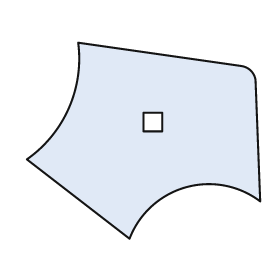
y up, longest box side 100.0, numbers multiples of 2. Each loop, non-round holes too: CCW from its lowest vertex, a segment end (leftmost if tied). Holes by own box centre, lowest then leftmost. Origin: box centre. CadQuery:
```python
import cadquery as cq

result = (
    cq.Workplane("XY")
    .moveTo(-6.0, -42.0)
    .threePointArc((18.0, -20.0), (50.0, -26.0))
    .lineTo(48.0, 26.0)
    .threePointArc((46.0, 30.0), (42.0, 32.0))
    .lineTo(-28.0, 42.0)
    .threePointArc((-32.0, 14.0), (-50.0, -8.0))
    .close()
    .moveTo(0.0, 4.0)
    .lineTo(8.0, 4.0)
    .lineTo(8.0, 12.0)
    .lineTo(0.0, 12.0)
    .close()
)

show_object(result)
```